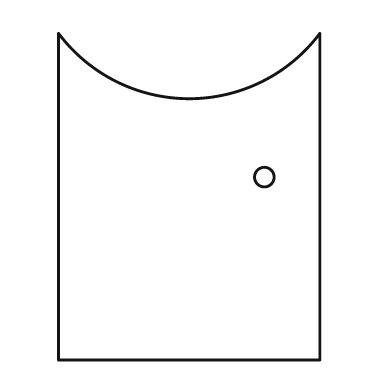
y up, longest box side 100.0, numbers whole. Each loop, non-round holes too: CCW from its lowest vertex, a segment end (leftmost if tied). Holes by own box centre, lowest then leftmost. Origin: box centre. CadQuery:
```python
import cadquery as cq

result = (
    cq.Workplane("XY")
    .moveTo(-40.0, -50.0)
    .lineTo(40.0, -50.0)
    .lineTo(40.0, 50.0)
    .threePointArc((0.0, 30.0), (-40.0, 50.0))
    .close()
    .moveTo(23.0, 6.0)
    .circle(3.0)
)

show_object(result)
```